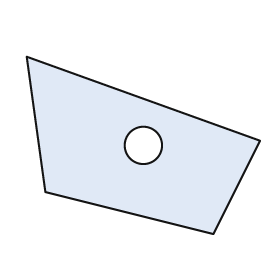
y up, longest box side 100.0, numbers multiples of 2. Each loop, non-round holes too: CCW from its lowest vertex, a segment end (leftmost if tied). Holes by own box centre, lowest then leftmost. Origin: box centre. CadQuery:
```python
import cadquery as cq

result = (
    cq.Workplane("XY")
    .moveTo(30.0, -38.0)
    .lineTo(50.0, 2.0)
    .lineTo(-50.0, 38.0)
    .lineTo(-42.0, -20.0)
    .close()
    .moveTo(0.0, 0.0)
    .circle(8.0)
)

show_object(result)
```